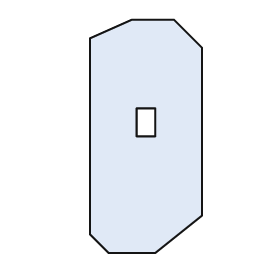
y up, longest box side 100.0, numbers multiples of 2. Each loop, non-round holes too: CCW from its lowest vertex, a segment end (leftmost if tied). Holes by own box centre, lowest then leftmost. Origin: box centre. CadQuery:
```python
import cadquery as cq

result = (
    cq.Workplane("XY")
    .moveTo(-16.0, -50.0)
    .lineTo(4.0, -50.0)
    .lineTo(24.0, -34.0)
    .lineTo(24.0, 38.0)
    .lineTo(12.0, 50.0)
    .lineTo(-6.0, 50.0)
    .lineTo(-24.0, 42.0)
    .lineTo(-24.0, -42.0)
    .close()
    .moveTo(-4.0, 0.0)
    .lineTo(4.0, 0.0)
    .lineTo(4.0, 12.0)
    .lineTo(-4.0, 12.0)
    .close()
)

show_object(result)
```